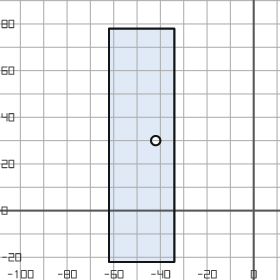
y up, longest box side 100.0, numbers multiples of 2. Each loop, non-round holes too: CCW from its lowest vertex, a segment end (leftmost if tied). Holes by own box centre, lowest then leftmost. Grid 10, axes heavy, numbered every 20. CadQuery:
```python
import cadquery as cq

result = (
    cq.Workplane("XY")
    .moveTo(-62.0, -22.0)
    .lineTo(-34.0, -22.0)
    .lineTo(-34.0, 78.0)
    .lineTo(-62.0, 78.0)
    .close()
    .moveTo(-42.0, 30.0)
    .circle(2.0)
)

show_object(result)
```